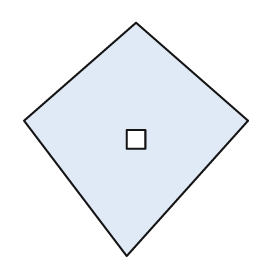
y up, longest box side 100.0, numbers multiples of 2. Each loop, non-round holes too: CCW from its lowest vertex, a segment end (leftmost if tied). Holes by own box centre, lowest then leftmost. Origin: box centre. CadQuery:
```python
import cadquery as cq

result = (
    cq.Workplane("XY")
    .moveTo(-4.0, -50.0)
    .lineTo(48.0, 8.0)
    .lineTo(0.0, 50.0)
    .lineTo(-48.0, 8.0)
    .close()
    .moveTo(-4.0, -4.0)
    .lineTo(4.0, -4.0)
    .lineTo(4.0, 4.0)
    .lineTo(-4.0, 4.0)
    .close()
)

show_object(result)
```